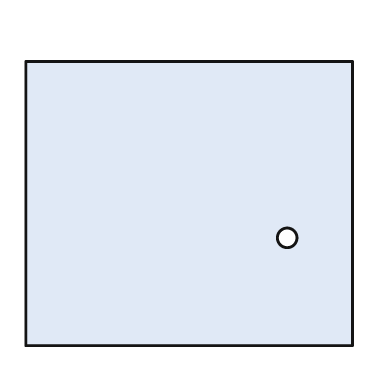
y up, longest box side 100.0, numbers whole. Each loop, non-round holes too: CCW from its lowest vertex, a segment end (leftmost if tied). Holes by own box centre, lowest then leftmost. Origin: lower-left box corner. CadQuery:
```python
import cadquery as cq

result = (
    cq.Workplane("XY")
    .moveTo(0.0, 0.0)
    .lineTo(100.0, 0.0)
    .lineTo(100.0, 87.0)
    .lineTo(0.0, 87.0)
    .close()
    .moveTo(80.0, 33.0)
    .circle(3.0)
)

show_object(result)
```